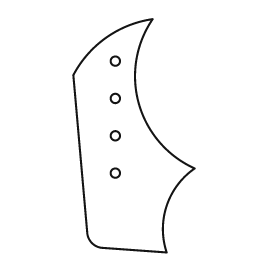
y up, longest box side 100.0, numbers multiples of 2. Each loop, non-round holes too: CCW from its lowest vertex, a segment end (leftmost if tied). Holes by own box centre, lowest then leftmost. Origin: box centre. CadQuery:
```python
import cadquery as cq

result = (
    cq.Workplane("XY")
    .moveTo(14.0, -50.0)
    .threePointArc((14.0, -30.0), (26.0, -14.0))
    .threePointArc((2.0, 14.0), (8.0, 50.0))
    .threePointArc((-12.0, 42.0), (-26.0, 26.0))
    .lineTo(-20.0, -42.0)
    .threePointArc((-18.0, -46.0), (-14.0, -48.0))
    .close()
    .moveTo(-8.0, -16.0)
    .circle(2.0)
    .moveTo(-8.0, 0.0)
    .circle(2.0)
    .moveTo(-8.0, 16.0)
    .circle(2.0)
    .moveTo(-8.0, 32.0)
    .circle(2.0)
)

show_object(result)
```